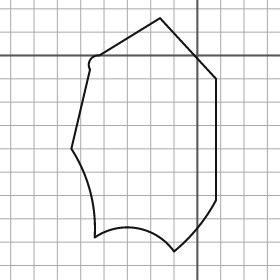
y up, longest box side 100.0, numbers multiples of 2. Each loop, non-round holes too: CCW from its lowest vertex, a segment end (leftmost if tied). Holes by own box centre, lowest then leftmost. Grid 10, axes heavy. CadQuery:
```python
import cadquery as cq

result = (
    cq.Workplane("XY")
    .moveTo(-10.0, -84.0)
    .threePointArc((0.0, -74.0), (8.0, -62.0))
    .lineTo(8.0, -10.0)
    .lineTo(-16.0, 16.0)
    .lineTo(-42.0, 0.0)
    .threePointArc((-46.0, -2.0), (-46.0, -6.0))
    .lineTo(-54.0, -40.0)
    .threePointArc((-46.0, -58.0), (-44.0, -78.0))
    .threePointArc((-26.0, -74.0), (-10.0, -84.0))
    .close()
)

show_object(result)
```